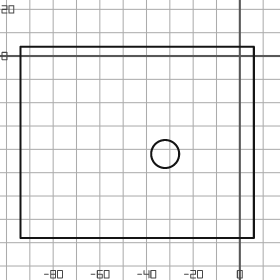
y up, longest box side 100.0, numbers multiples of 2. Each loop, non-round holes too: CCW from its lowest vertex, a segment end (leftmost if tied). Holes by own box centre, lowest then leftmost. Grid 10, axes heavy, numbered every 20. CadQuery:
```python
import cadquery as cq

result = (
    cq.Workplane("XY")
    .moveTo(-94.0, -78.0)
    .lineTo(6.0, -78.0)
    .lineTo(6.0, 4.0)
    .lineTo(-94.0, 4.0)
    .close()
    .moveTo(-32.0, -42.0)
    .circle(6.0)
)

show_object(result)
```